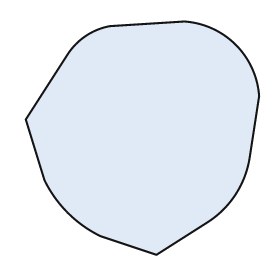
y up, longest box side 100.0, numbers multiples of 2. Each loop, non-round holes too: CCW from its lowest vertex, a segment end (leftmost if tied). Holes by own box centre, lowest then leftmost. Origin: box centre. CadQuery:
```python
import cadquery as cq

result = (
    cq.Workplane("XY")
    .moveTo(6.0, -50.0)
    .lineTo(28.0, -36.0)
    .threePointArc((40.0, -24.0), (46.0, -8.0))
    .lineTo(50.0, 18.0)
    .threePointArc((40.0, 40.0), (18.0, 50.0))
    .lineTo(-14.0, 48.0)
    .threePointArc((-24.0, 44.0), (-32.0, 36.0))
    .lineTo(-50.0, 8.0)
    .lineTo(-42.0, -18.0)
    .threePointArc((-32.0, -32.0), (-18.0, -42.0))
    .close()
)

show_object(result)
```